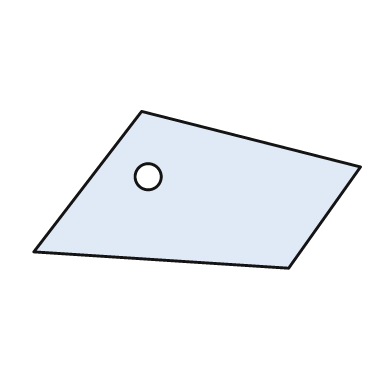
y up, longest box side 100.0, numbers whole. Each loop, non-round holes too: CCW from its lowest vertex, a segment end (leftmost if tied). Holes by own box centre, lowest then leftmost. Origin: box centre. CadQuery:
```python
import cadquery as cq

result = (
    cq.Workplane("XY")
    .moveTo(28.0, -24.0)
    .lineTo(50.0, 7.0)
    .lineTo(-17.0, 24.0)
    .lineTo(-50.0, -19.0)
    .close()
    .moveTo(-15.0, 4.0)
    .circle(4.0)
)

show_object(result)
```